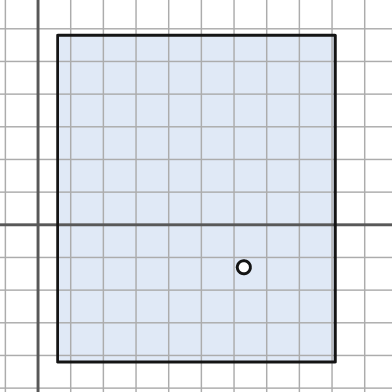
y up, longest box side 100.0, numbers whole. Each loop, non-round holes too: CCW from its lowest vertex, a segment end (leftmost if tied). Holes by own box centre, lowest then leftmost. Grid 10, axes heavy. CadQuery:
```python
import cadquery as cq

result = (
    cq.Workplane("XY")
    .moveTo(6.0, -42.0)
    .lineTo(91.0, -42.0)
    .lineTo(91.0, 58.0)
    .lineTo(6.0, 58.0)
    .close()
    .moveTo(63.0, -13.0)
    .circle(2.0)
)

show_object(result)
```